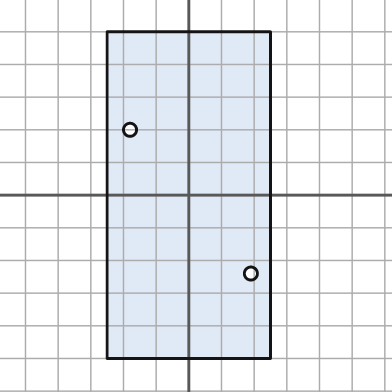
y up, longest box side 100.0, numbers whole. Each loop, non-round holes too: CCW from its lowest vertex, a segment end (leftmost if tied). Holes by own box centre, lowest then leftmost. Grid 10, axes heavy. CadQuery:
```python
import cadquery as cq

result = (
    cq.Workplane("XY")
    .moveTo(-25.0, -50.0)
    .lineTo(25.0, -50.0)
    .lineTo(25.0, 50.0)
    .lineTo(-25.0, 50.0)
    .close()
    .moveTo(19.0, -24.0)
    .circle(2.0)
    .moveTo(-18.0, 20.0)
    .circle(2.0)
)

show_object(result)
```